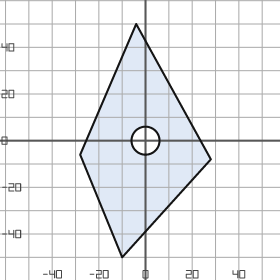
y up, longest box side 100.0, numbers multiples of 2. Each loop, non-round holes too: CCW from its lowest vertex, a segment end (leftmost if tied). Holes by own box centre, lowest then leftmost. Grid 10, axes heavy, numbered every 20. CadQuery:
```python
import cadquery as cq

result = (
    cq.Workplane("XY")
    .moveTo(-10.0, -50.0)
    .lineTo(28.0, -8.0)
    .lineTo(-4.0, 50.0)
    .lineTo(-28.0, -6.0)
    .close()
    .moveTo(0.0, 0.0)
    .circle(6.0)
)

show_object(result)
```